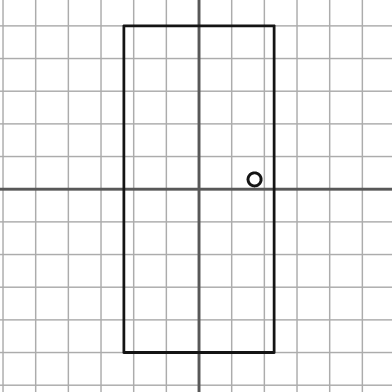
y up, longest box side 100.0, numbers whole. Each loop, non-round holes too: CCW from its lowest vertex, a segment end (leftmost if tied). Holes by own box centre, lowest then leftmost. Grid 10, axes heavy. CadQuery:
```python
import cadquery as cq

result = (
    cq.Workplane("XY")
    .moveTo(-23.0, -50.0)
    .lineTo(23.0, -50.0)
    .lineTo(23.0, 50.0)
    .lineTo(-23.0, 50.0)
    .close()
    .moveTo(17.0, 3.0)
    .circle(2.0)
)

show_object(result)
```